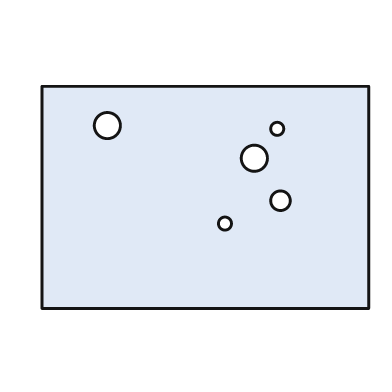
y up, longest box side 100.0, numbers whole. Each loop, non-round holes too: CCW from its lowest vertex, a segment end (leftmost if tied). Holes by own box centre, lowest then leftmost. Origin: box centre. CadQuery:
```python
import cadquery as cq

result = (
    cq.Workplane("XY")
    .moveTo(-50.0, -34.0)
    .lineTo(50.0, -34.0)
    .lineTo(50.0, 34.0)
    .lineTo(-50.0, 34.0)
    .close()
    .moveTo(6.0, -8.0)
    .circle(2.0)
    .moveTo(23.0, -1.0)
    .circle(3.0)
    .moveTo(15.0, 12.0)
    .circle(4.0)
    .moveTo(22.0, 21.0)
    .circle(2.0)
    .moveTo(-30.0, 22.0)
    .circle(4.0)
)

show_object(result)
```